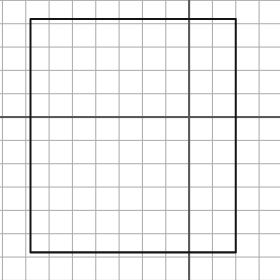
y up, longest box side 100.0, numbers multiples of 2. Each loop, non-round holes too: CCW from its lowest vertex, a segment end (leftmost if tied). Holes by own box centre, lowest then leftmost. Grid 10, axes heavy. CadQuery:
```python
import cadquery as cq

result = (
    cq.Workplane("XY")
    .moveTo(-68.0, -58.0)
    .lineTo(20.0, -58.0)
    .lineTo(20.0, 42.0)
    .lineTo(-68.0, 42.0)
    .close()
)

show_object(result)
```